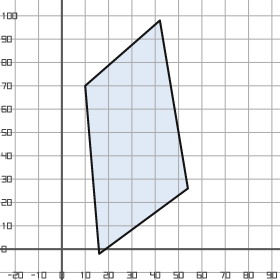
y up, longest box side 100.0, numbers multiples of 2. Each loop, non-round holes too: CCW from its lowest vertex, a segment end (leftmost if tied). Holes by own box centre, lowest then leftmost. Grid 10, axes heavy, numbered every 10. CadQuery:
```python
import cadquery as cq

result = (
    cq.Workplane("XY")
    .moveTo(16.0, -2.0)
    .lineTo(54.0, 26.0)
    .lineTo(42.0, 98.0)
    .lineTo(10.0, 70.0)
    .close()
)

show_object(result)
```